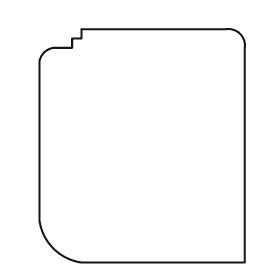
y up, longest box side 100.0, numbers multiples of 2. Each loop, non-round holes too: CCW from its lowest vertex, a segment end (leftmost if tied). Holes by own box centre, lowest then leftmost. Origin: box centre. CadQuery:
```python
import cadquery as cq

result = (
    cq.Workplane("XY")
    .moveTo(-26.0, -50.0)
    .lineTo(44.0, -50.0)
    .lineTo(44.0, 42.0)
    .threePointArc((42.0, 48.0), (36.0, 50.0))
    .lineTo(-26.0, 50.0)
    .lineTo(-26.0, 46.0)
    .lineTo(-30.0, 46.0)
    .lineTo(-30.0, 42.0)
    .lineTo(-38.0, 42.0)
    .threePointArc((-42.0, 40.0), (-44.0, 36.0))
    .lineTo(-44.0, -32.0)
    .threePointArc((-38.0, -44.0), (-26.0, -50.0))
    .close()
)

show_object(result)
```